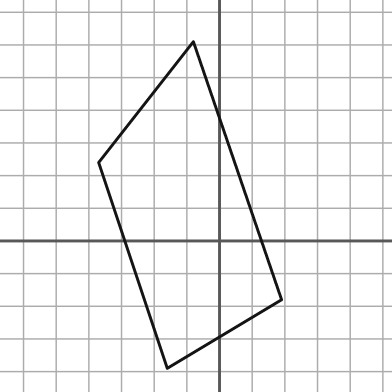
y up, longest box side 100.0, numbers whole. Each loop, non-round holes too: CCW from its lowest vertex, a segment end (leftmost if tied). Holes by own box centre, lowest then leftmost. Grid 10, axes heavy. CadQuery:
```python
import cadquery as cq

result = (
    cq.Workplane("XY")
    .moveTo(-16.0, -39.0)
    .lineTo(19.0, -18.0)
    .lineTo(-8.0, 61.0)
    .lineTo(-37.0, 24.0)
    .close()
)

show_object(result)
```